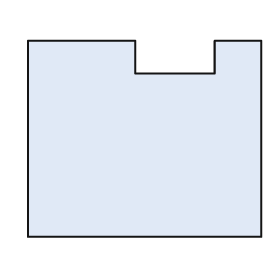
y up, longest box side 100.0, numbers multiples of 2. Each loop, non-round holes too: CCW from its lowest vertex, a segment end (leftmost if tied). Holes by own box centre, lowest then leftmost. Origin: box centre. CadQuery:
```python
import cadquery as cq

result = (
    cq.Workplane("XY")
    .moveTo(-50.0, -42.0)
    .lineTo(50.0, -42.0)
    .lineTo(50.0, 42.0)
    .lineTo(30.0, 42.0)
    .lineTo(30.0, 28.0)
    .lineTo(-4.0, 28.0)
    .lineTo(-4.0, 42.0)
    .lineTo(-50.0, 42.0)
    .close()
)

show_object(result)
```